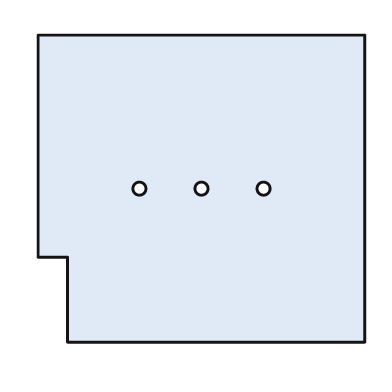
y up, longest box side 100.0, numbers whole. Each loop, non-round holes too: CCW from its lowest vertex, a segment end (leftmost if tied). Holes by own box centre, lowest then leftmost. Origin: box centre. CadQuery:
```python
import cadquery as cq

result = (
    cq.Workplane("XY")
    .moveTo(-41.0, -47.0)
    .lineTo(50.0, -47.0)
    .lineTo(50.0, 47.0)
    .lineTo(-50.0, 47.0)
    .lineTo(-50.0, -21.0)
    .lineTo(-41.0, -21.0)
    .close()
    .moveTo(-19.0, 0.0)
    .circle(2.0)
    .moveTo(0.0, 0.0)
    .circle(2.0)
    .moveTo(19.0, 0.0)
    .circle(2.0)
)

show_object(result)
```